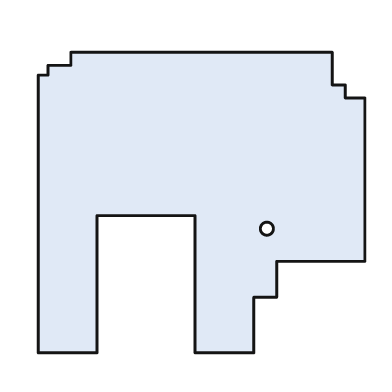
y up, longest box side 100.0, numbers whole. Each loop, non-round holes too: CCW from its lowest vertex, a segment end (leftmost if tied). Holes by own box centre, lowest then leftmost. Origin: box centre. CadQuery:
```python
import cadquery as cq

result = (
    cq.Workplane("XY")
    .moveTo(-50.0, -46.0)
    .lineTo(-32.0, -46.0)
    .lineTo(-32.0, -4.0)
    .lineTo(-2.0, -4.0)
    .lineTo(-2.0, -46.0)
    .lineTo(16.0, -46.0)
    .lineTo(16.0, -29.0)
    .lineTo(23.0, -29.0)
    .lineTo(23.0, -18.0)
    .lineTo(50.0, -18.0)
    .lineTo(50.0, 32.0)
    .lineTo(44.0, 32.0)
    .lineTo(44.0, 36.0)
    .lineTo(40.0, 36.0)
    .lineTo(40.0, 46.0)
    .lineTo(-40.0, 46.0)
    .lineTo(-40.0, 42.0)
    .lineTo(-47.0, 42.0)
    .lineTo(-47.0, 39.0)
    .lineTo(-50.0, 39.0)
    .close()
    .moveTo(20.0, -8.0)
    .circle(2.0)
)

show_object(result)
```